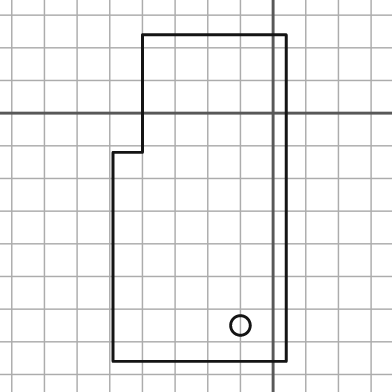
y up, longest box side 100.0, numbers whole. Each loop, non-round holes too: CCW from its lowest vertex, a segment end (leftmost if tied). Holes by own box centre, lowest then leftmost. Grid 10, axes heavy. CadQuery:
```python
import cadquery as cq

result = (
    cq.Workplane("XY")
    .moveTo(-49.0, -76.0)
    .lineTo(4.0, -76.0)
    .lineTo(4.0, 24.0)
    .lineTo(-40.0, 24.0)
    .lineTo(-40.0, -12.0)
    .lineTo(-49.0, -12.0)
    .close()
    .moveTo(-10.0, -65.0)
    .circle(3.0)
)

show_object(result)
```